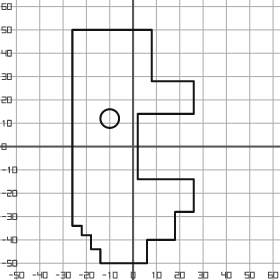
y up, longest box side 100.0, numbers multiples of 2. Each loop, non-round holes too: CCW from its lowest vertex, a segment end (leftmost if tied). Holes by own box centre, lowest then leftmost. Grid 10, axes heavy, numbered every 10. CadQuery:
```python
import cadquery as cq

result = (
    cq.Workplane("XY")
    .moveTo(-14.0, -50.0)
    .lineTo(6.0, -50.0)
    .lineTo(6.0, -40.0)
    .lineTo(18.0, -40.0)
    .lineTo(18.0, -28.0)
    .lineTo(26.0, -28.0)
    .lineTo(26.0, -14.0)
    .lineTo(2.0, -14.0)
    .lineTo(2.0, 14.0)
    .lineTo(26.0, 14.0)
    .lineTo(26.0, 28.0)
    .lineTo(8.0, 28.0)
    .lineTo(8.0, 50.0)
    .lineTo(-26.0, 50.0)
    .lineTo(-26.0, -34.0)
    .lineTo(-22.0, -34.0)
    .lineTo(-22.0, -38.0)
    .lineTo(-18.0, -38.0)
    .lineTo(-18.0, -44.0)
    .lineTo(-14.0, -44.0)
    .close()
    .moveTo(-10.0, 12.0)
    .circle(4.0)
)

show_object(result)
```